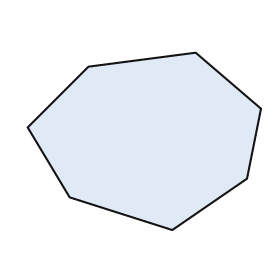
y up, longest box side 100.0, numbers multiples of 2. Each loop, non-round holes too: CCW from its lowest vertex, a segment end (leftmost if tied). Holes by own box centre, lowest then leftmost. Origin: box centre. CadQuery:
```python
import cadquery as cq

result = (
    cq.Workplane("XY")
    .moveTo(12.0, -38.0)
    .lineTo(44.0, -16.0)
    .lineTo(50.0, 14.0)
    .lineTo(22.0, 38.0)
    .lineTo(-24.0, 32.0)
    .lineTo(-50.0, 6.0)
    .lineTo(-32.0, -24.0)
    .close()
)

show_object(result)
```